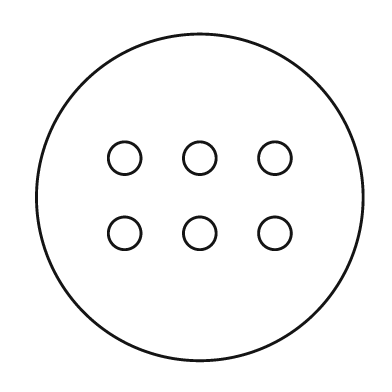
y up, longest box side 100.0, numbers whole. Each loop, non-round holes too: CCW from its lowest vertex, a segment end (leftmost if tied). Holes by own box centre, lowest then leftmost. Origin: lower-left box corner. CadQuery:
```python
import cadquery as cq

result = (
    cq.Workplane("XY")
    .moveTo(50.0, 50.0)
    .circle(50.0)
    .moveTo(27.0, 39.0)
    .circle(5.0)
    .moveTo(50.0, 39.0)
    .circle(5.0)
    .moveTo(73.0, 39.0)
    .circle(5.0)
    .moveTo(27.0, 62.0)
    .circle(5.0)
    .moveTo(50.0, 62.0)
    .circle(5.0)
    .moveTo(73.0, 62.0)
    .circle(5.0)
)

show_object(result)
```